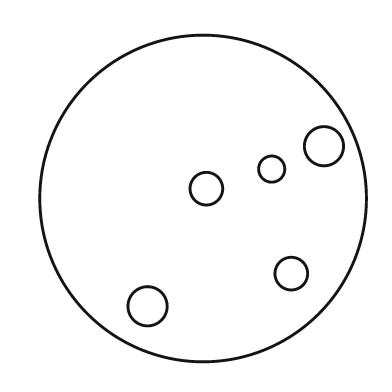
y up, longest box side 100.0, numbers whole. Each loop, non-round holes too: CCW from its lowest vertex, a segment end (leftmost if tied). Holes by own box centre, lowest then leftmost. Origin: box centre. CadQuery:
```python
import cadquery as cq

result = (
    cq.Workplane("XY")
    .moveTo(0.0, 0.0)
    .circle(50.0)
    .moveTo(-17.0, -33.0)
    .circle(6.0)
    .moveTo(27.0, -23.0)
    .circle(5.0)
    .moveTo(1.0, 3.0)
    .circle(5.0)
    .moveTo(21.0, 9.0)
    .circle(4.0)
    .moveTo(37.0, 16.0)
    .circle(6.0)
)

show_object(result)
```